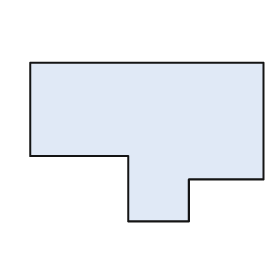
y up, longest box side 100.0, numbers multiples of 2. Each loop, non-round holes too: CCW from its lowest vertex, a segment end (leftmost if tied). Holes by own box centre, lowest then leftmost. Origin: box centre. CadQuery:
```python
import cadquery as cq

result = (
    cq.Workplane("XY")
    .moveTo(-8.0, -34.0)
    .lineTo(18.0, -34.0)
    .lineTo(18.0, -16.0)
    .lineTo(50.0, -16.0)
    .lineTo(50.0, 34.0)
    .lineTo(-50.0, 34.0)
    .lineTo(-50.0, -6.0)
    .lineTo(-8.0, -6.0)
    .close()
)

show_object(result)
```